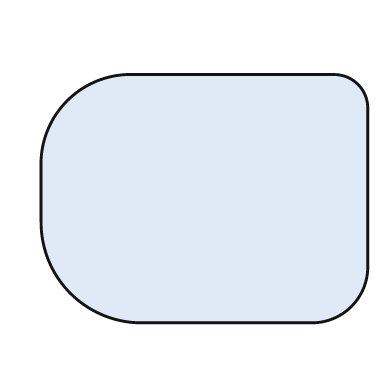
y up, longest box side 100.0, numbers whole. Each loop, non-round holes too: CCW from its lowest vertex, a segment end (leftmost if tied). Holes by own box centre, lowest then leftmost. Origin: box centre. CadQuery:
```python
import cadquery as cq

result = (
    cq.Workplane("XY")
    .moveTo(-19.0, -38.0)
    .lineTo(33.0, -38.0)
    .threePointArc((45.0, -33.0), (50.0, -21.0))
    .lineTo(50.0, 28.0)
    .threePointArc((47.0, 35.0), (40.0, 38.0))
    .lineTo(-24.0, 38.0)
    .threePointArc((-42.0, 30.0), (-50.0, 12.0))
    .lineTo(-50.0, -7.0)
    .threePointArc((-41.0, -29.0), (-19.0, -38.0))
    .close()
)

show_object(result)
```